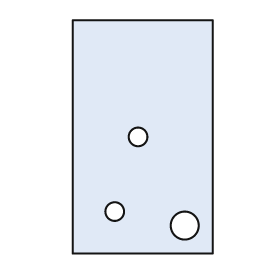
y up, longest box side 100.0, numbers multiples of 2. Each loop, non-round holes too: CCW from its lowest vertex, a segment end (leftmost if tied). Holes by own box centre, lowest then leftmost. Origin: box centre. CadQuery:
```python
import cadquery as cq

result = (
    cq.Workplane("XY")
    .moveTo(-30.0, -50.0)
    .lineTo(30.0, -50.0)
    .lineTo(30.0, 50.0)
    .lineTo(-30.0, 50.0)
    .close()
    .moveTo(18.0, -38.0)
    .circle(6.0)
    .moveTo(-12.0, -32.0)
    .circle(4.0)
    .moveTo(-2.0, 0.0)
    .circle(4.0)
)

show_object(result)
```